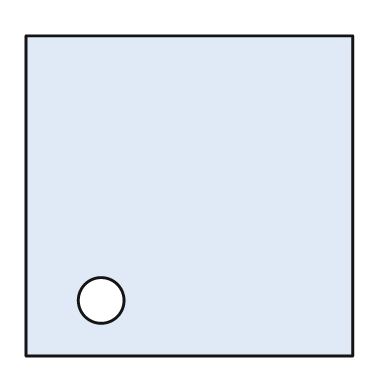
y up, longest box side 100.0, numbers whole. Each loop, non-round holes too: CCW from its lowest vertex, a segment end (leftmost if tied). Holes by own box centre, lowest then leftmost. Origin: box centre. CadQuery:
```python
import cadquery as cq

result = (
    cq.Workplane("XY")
    .moveTo(-50.0, -49.0)
    .lineTo(50.0, -49.0)
    .lineTo(50.0, 49.0)
    .lineTo(-50.0, 49.0)
    .close()
    .moveTo(-27.0, -32.0)
    .circle(7.0)
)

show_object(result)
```